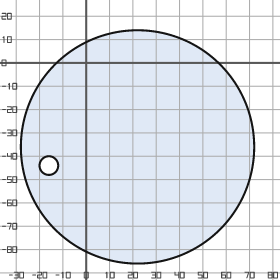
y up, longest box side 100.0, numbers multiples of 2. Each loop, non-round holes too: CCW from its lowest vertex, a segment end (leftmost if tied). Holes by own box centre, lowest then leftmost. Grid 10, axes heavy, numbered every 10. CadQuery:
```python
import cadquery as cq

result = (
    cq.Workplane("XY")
    .moveTo(22.0, -36.0)
    .circle(50.0)
    .moveTo(-16.0, -44.0)
    .circle(4.0)
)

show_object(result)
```